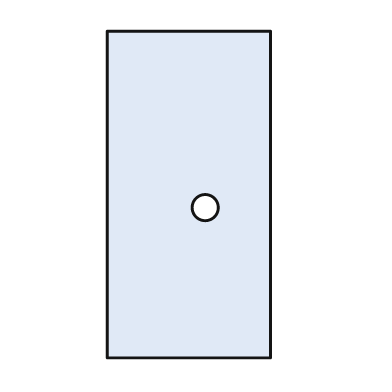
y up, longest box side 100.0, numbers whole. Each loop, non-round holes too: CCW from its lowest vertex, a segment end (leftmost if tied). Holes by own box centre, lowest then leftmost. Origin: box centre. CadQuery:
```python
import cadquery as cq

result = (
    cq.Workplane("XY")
    .moveTo(-25.0, -50.0)
    .lineTo(25.0, -50.0)
    .lineTo(25.0, 50.0)
    .lineTo(-25.0, 50.0)
    .close()
    .moveTo(5.0, -4.0)
    .circle(4.0)
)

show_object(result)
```